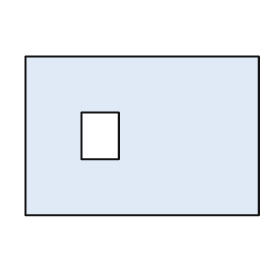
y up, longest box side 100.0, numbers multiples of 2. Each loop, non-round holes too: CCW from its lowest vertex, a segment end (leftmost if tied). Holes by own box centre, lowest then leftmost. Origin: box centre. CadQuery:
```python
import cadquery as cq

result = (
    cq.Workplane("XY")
    .moveTo(-50.0, -34.0)
    .lineTo(50.0, -34.0)
    .lineTo(50.0, 34.0)
    .lineTo(-50.0, 34.0)
    .close()
    .moveTo(-26.0, -10.0)
    .lineTo(-10.0, -10.0)
    .lineTo(-10.0, 10.0)
    .lineTo(-26.0, 10.0)
    .close()
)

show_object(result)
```